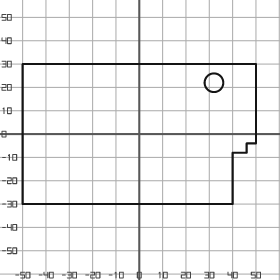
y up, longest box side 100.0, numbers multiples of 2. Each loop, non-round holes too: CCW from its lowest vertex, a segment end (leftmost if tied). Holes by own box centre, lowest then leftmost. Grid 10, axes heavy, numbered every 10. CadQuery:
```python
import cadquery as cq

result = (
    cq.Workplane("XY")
    .moveTo(-50.0, -30.0)
    .lineTo(40.0, -30.0)
    .lineTo(40.0, -8.0)
    .lineTo(46.0, -8.0)
    .lineTo(46.0, -4.0)
    .lineTo(50.0, -4.0)
    .lineTo(50.0, 30.0)
    .lineTo(-50.0, 30.0)
    .close()
    .moveTo(32.0, 22.0)
    .circle(4.0)
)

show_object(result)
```